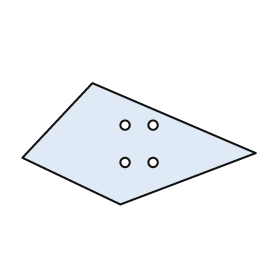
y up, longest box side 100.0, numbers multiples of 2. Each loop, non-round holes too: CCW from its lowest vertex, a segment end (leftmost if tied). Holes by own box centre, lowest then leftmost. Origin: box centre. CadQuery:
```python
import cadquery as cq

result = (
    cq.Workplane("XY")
    .moveTo(-8.0, -26.0)
    .lineTo(50.0, -4.0)
    .lineTo(-20.0, 26.0)
    .lineTo(-50.0, -6.0)
    .close()
    .moveTo(-6.0, -8.0)
    .circle(2.0)
    .moveTo(6.0, -8.0)
    .circle(2.0)
    .moveTo(-6.0, 8.0)
    .circle(2.0)
    .moveTo(6.0, 8.0)
    .circle(2.0)
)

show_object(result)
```